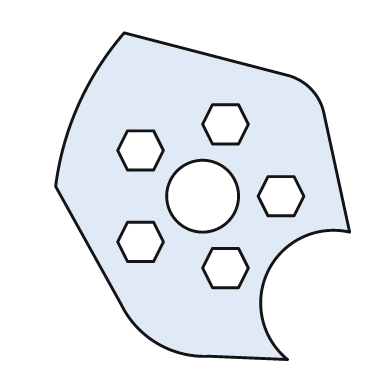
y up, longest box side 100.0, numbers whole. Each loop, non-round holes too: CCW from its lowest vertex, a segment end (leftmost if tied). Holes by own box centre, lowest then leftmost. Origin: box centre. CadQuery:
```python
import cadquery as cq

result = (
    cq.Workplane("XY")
    .moveTo(26.0, -50.0)
    .threePointArc((20.0, -23.0), (45.0, -11.0))
    .lineTo(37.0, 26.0)
    .threePointArc((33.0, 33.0), (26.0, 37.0))
    .lineTo(-24.0, 50.0)
    .threePointArc((-38.0, 28.0), (-45.0, 3.0))
    .lineTo(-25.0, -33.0)
    .threePointArc((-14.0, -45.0), (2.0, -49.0))
    .close()
    .moveTo(3.0, -28.0)
    .lineTo(11.0, -28.0)
    .lineTo(14.0, -22.0)
    .lineTo(11.0, -16.0)
    .lineTo(3.0, -16.0)
    .lineTo(0.0, -22.0)
    .close()
    .moveTo(-23.0, -20.0)
    .lineTo(-15.0, -20.0)
    .lineTo(-12.0, -14.0)
    .lineTo(-15.0, -8.0)
    .lineTo(-23.0, -8.0)
    .lineTo(-26.0, -14.0)
    .close()
    .moveTo(0.0, 0.0)
    .circle(11.0)
    .moveTo(20.0, -6.0)
    .lineTo(28.0, -6.0)
    .lineTo(31.0, 0.0)
    .lineTo(28.0, 6.0)
    .lineTo(20.0, 6.0)
    .lineTo(17.0, 0.0)
    .close()
    .moveTo(-23.0, 8.0)
    .lineTo(-15.0, 8.0)
    .lineTo(-12.0, 14.0)
    .lineTo(-15.0, 20.0)
    .lineTo(-23.0, 20.0)
    .lineTo(-26.0, 14.0)
    .close()
    .moveTo(3.0, 16.0)
    .lineTo(11.0, 16.0)
    .lineTo(14.0, 22.0)
    .lineTo(11.0, 28.0)
    .lineTo(3.0, 28.0)
    .lineTo(0.0, 22.0)
    .close()
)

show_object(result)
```